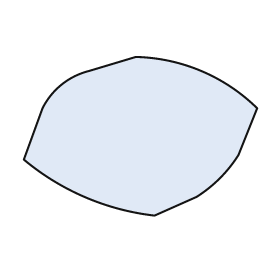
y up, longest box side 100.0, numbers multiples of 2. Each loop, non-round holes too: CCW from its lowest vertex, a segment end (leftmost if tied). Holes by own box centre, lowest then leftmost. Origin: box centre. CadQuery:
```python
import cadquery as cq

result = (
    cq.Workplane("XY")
    .moveTo(6.0, -34.0)
    .lineTo(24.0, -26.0)
    .threePointArc((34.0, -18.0), (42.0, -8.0))
    .lineTo(50.0, 12.0)
    .threePointArc((26.0, 28.0), (-2.0, 34.0))
    .lineTo(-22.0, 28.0)
    .threePointArc((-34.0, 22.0), (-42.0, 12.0))
    .lineTo(-50.0, -10.0)
    .threePointArc((-24.0, -26.0), (6.0, -34.0))
    .close()
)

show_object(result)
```